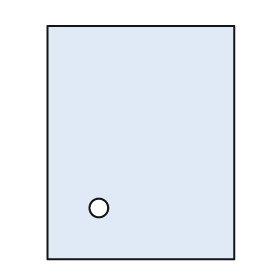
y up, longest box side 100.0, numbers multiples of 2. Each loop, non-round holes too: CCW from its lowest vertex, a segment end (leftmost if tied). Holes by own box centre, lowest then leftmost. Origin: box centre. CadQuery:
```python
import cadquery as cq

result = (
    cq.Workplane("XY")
    .moveTo(-40.0, -50.0)
    .lineTo(40.0, -50.0)
    .lineTo(40.0, 50.0)
    .lineTo(-40.0, 50.0)
    .close()
    .moveTo(-18.0, -28.0)
    .circle(4.0)
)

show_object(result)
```